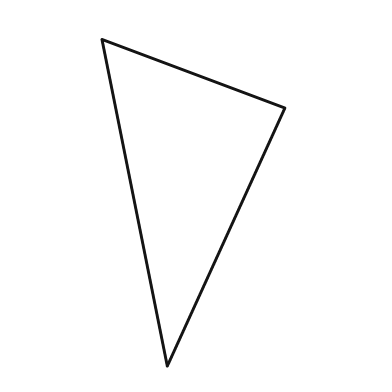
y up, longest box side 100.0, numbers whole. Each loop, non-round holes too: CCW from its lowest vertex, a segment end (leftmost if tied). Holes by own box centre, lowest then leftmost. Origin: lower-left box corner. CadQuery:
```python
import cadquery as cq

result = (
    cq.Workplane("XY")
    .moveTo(20.0, 0.0)
    .lineTo(56.0, 79.0)
    .lineTo(0.0, 100.0)
    .close()
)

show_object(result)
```